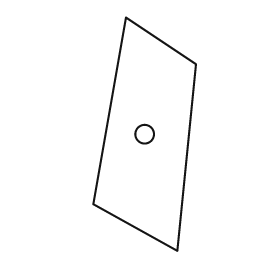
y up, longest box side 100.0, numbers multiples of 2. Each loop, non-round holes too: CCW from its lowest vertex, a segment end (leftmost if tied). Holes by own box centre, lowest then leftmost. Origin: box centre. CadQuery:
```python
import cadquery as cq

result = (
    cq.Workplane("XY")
    .moveTo(14.0, -50.0)
    .lineTo(22.0, 30.0)
    .lineTo(-8.0, 50.0)
    .lineTo(-22.0, -30.0)
    .close()
    .moveTo(0.0, 0.0)
    .circle(4.0)
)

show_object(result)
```